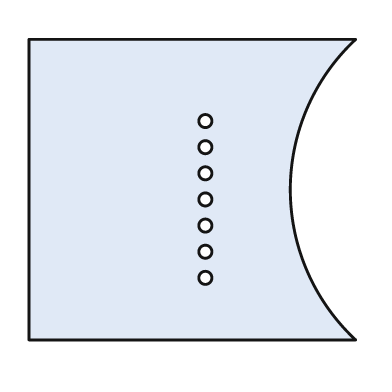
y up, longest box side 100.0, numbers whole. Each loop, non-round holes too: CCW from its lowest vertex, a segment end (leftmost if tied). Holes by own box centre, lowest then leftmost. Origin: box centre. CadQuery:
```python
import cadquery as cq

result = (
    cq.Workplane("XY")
    .moveTo(-50.0, -46.0)
    .lineTo(50.0, -46.0)
    .threePointArc((30.0, 0.0), (50.0, 46.0))
    .lineTo(-50.0, 46.0)
    .close()
    .moveTo(4.0, -27.0)
    .circle(2.0)
    .moveTo(4.0, -19.0)
    .circle(2.0)
    .moveTo(4.0, -11.0)
    .circle(2.0)
    .moveTo(4.0, -3.0)
    .circle(2.0)
    .moveTo(4.0, 5.0)
    .circle(2.0)
    .moveTo(4.0, 13.0)
    .circle(2.0)
    .moveTo(4.0, 21.0)
    .circle(2.0)
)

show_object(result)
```